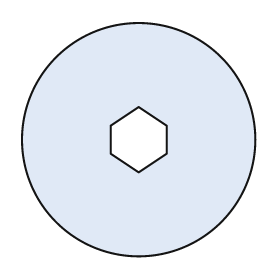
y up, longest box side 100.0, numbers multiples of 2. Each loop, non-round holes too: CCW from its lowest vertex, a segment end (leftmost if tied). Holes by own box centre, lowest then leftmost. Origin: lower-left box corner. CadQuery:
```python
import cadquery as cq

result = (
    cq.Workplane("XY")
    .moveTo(50.0, 50.0)
    .circle(50.0)
    .moveTo(50.0, 36.0)
    .lineTo(62.0, 44.0)
    .lineTo(62.0, 56.0)
    .lineTo(50.0, 64.0)
    .lineTo(38.0, 56.0)
    .lineTo(38.0, 44.0)
    .close()
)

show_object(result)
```